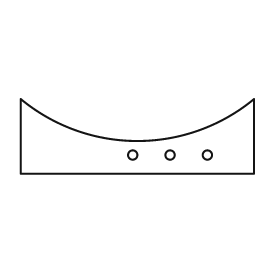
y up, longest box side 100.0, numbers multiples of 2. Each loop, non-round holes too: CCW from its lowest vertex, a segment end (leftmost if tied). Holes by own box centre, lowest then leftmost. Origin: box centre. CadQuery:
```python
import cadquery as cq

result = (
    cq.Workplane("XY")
    .moveTo(-50.0, -16.0)
    .lineTo(50.0, -16.0)
    .lineTo(50.0, 16.0)
    .threePointArc((0.0, -2.0), (-50.0, 16.0))
    .close()
    .moveTo(-2.0, -8.0)
    .circle(2.0)
    .moveTo(14.0, -8.0)
    .circle(2.0)
    .moveTo(30.0, -8.0)
    .circle(2.0)
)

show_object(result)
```